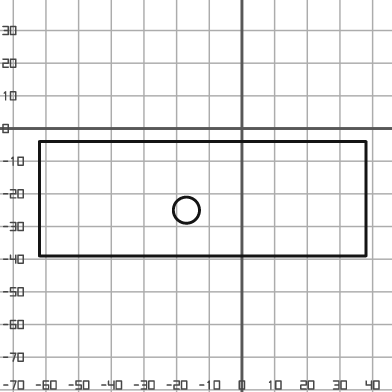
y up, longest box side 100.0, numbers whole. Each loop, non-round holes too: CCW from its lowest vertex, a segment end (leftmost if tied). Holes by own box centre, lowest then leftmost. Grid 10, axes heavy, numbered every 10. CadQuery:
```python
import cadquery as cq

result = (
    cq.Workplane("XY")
    .moveTo(-62.0, -39.0)
    .lineTo(38.0, -39.0)
    .lineTo(38.0, -4.0)
    .lineTo(-62.0, -4.0)
    .close()
    .moveTo(-17.0, -25.0)
    .circle(4.0)
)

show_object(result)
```